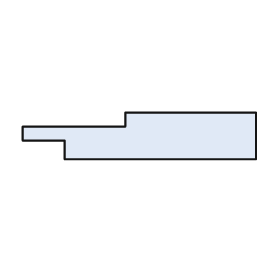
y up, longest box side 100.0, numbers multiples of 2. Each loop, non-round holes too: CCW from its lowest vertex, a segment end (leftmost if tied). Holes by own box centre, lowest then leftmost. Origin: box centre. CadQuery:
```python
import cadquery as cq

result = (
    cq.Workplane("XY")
    .moveTo(-32.0, -10.0)
    .lineTo(50.0, -10.0)
    .lineTo(50.0, 10.0)
    .lineTo(-6.0, 10.0)
    .lineTo(-6.0, 4.0)
    .lineTo(-50.0, 4.0)
    .lineTo(-50.0, -2.0)
    .lineTo(-32.0, -2.0)
    .close()
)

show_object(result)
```